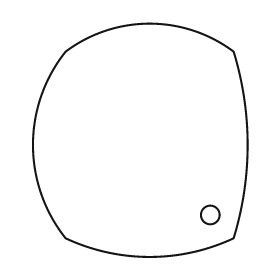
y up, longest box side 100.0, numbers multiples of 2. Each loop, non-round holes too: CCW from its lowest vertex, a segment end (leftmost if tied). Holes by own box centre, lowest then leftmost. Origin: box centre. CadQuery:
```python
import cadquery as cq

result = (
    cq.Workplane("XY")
    .moveTo(-32.0, -42.0)
    .threePointArc((4.0, -50.0), (40.0, -42.0))
    .threePointArc((46.0, -2.0), (40.0, 38.0))
    .threePointArc((4.0, 50.0), (-32.0, 38.0))
    .threePointArc((-46.0, -2.0), (-32.0, -42.0))
    .close()
    .moveTo(30.0, -32.0)
    .circle(4.0)
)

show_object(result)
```